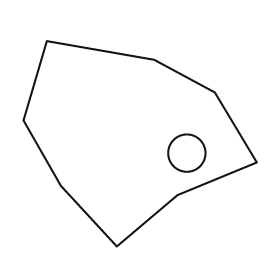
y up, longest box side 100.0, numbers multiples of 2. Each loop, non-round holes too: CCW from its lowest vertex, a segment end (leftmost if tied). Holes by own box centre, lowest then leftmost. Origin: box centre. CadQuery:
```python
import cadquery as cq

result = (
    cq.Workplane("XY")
    .moveTo(-10.0, -44.0)
    .lineTo(16.0, -22.0)
    .lineTo(50.0, -8.0)
    .lineTo(32.0, 22.0)
    .lineTo(6.0, 36.0)
    .lineTo(-40.0, 44.0)
    .lineTo(-50.0, 10.0)
    .lineTo(-34.0, -18.0)
    .close()
    .moveTo(20.0, -4.0)
    .circle(8.0)
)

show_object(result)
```